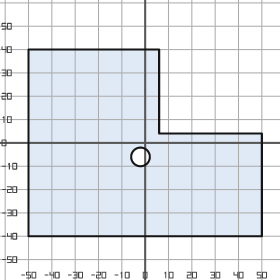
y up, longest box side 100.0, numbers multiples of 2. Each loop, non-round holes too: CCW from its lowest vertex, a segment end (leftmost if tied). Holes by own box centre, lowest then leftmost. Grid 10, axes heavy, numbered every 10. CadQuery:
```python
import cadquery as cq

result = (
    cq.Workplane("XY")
    .moveTo(-50.0, -40.0)
    .lineTo(50.0, -40.0)
    .lineTo(50.0, 4.0)
    .lineTo(6.0, 4.0)
    .lineTo(6.0, 40.0)
    .lineTo(-50.0, 40.0)
    .close()
    .moveTo(-2.0, -6.0)
    .circle(4.0)
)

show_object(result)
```